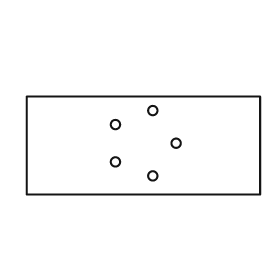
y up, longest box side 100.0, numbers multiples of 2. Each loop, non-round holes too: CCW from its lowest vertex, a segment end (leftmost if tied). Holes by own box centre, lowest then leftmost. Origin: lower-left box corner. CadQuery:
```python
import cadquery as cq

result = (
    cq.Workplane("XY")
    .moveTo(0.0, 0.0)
    .lineTo(100.0, 0.0)
    .lineTo(100.0, 42.0)
    .lineTo(0.0, 42.0)
    .close()
    .moveTo(54.0, 8.0)
    .circle(2.0)
    .moveTo(38.0, 14.0)
    .circle(2.0)
    .moveTo(64.0, 22.0)
    .circle(2.0)
    .moveTo(38.0, 30.0)
    .circle(2.0)
    .moveTo(54.0, 36.0)
    .circle(2.0)
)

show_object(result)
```